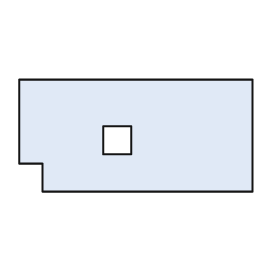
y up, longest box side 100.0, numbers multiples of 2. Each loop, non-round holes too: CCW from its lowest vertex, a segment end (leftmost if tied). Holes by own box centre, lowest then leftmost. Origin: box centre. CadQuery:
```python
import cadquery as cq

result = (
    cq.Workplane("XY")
    .moveTo(-40.0, -24.0)
    .lineTo(50.0, -24.0)
    .lineTo(50.0, 24.0)
    .lineTo(-50.0, 24.0)
    .lineTo(-50.0, -12.0)
    .lineTo(-40.0, -12.0)
    .close()
    .moveTo(-14.0, -8.0)
    .lineTo(-2.0, -8.0)
    .lineTo(-2.0, 4.0)
    .lineTo(-14.0, 4.0)
    .close()
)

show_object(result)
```